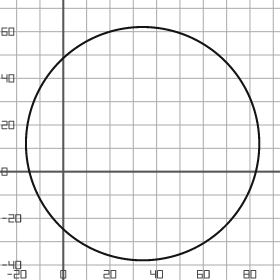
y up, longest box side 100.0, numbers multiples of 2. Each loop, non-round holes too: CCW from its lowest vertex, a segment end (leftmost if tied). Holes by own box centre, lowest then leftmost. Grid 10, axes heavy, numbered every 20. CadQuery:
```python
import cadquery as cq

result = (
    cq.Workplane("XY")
    .moveTo(34.0, 12.0)
    .circle(50.0)
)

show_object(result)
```